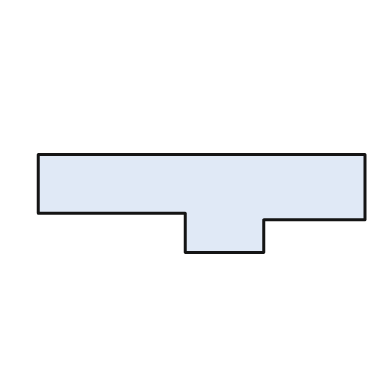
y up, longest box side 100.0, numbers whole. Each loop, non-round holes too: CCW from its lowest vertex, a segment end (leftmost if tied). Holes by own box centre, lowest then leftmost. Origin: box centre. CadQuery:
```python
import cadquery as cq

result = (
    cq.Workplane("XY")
    .moveTo(-5.0, -15.0)
    .lineTo(19.0, -15.0)
    .lineTo(19.0, -5.0)
    .lineTo(50.0, -5.0)
    .lineTo(50.0, 15.0)
    .lineTo(-50.0, 15.0)
    .lineTo(-50.0, -3.0)
    .lineTo(-5.0, -3.0)
    .close()
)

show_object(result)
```